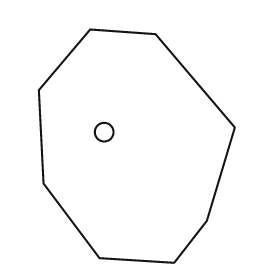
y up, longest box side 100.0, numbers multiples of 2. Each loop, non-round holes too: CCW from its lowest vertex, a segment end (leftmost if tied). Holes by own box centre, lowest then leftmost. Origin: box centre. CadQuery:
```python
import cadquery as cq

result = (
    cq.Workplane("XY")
    .moveTo(16.0, -50.0)
    .lineTo(30.0, -32.0)
    .lineTo(42.0, 8.0)
    .lineTo(8.0, 48.0)
    .lineTo(-20.0, 50.0)
    .lineTo(-42.0, 24.0)
    .lineTo(-40.0, -16.0)
    .lineTo(-16.0, -48.0)
    .close()
    .moveTo(-14.0, 6.0)
    .circle(4.0)
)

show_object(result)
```